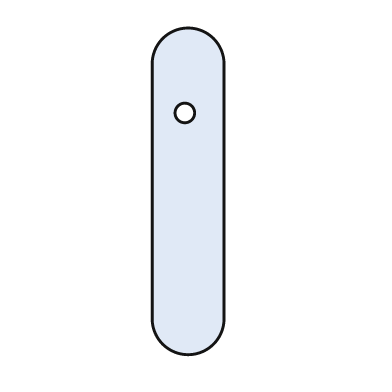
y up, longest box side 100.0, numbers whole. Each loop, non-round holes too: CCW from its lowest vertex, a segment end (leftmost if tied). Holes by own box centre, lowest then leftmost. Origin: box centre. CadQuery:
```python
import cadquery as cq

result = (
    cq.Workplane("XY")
    .moveTo(-11.0, -39.0)
    .threePointArc((0.0, -50.0), (11.0, -39.0))
    .lineTo(11.0, 39.0)
    .threePointArc((0.0, 50.0), (-11.0, 39.0))
    .close()
    .moveTo(-1.0, 24.0)
    .circle(3.0)
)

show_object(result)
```